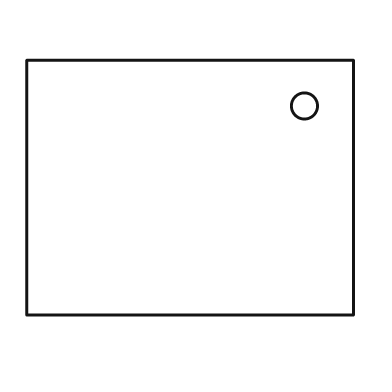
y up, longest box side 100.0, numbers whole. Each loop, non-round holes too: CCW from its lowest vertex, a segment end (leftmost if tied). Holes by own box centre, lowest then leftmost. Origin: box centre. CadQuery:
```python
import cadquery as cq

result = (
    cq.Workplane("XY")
    .moveTo(-50.0, -39.0)
    .lineTo(50.0, -39.0)
    .lineTo(50.0, 39.0)
    .lineTo(-50.0, 39.0)
    .close()
    .moveTo(35.0, 25.0)
    .circle(4.0)
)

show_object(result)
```